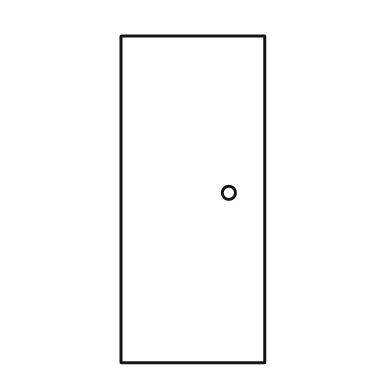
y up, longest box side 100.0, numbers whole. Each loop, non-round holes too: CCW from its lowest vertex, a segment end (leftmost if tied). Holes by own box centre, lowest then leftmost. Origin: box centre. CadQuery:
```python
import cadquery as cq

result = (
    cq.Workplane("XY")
    .moveTo(-22.0, -50.0)
    .lineTo(22.0, -50.0)
    .lineTo(22.0, 50.0)
    .lineTo(-22.0, 50.0)
    .close()
    .moveTo(11.0, 2.0)
    .circle(2.0)
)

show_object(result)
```